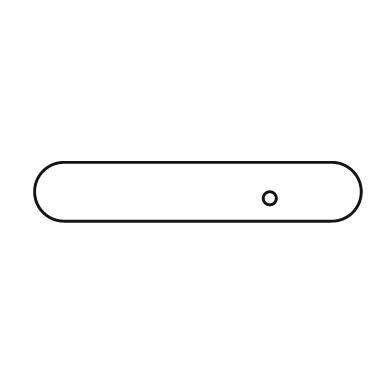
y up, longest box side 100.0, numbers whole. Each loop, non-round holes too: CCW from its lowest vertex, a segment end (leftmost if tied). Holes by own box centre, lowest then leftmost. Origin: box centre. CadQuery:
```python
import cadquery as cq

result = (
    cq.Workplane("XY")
    .moveTo(-41.0, -9.0)
    .lineTo(41.0, -9.0)
    .threePointArc((50.0, 0.0), (41.0, 9.0))
    .lineTo(-41.0, 9.0)
    .threePointArc((-50.0, 0.0), (-41.0, -9.0))
    .close()
    .moveTo(22.0, -2.0)
    .circle(2.0)
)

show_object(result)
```